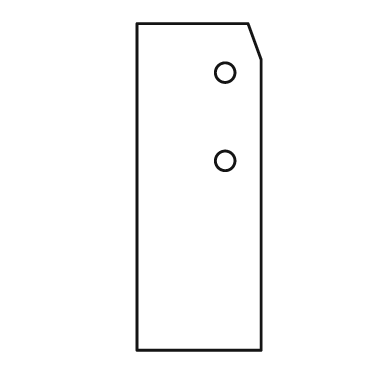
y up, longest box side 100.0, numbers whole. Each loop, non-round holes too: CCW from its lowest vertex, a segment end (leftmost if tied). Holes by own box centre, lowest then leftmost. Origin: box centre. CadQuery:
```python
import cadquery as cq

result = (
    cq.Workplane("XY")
    .moveTo(-19.0, -50.0)
    .lineTo(19.0, -50.0)
    .lineTo(19.0, 39.0)
    .lineTo(15.0, 50.0)
    .lineTo(-19.0, 50.0)
    .close()
    .moveTo(8.0, 8.0)
    .circle(3.0)
    .moveTo(8.0, 35.0)
    .circle(3.0)
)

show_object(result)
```